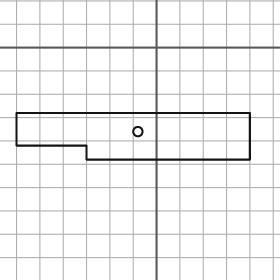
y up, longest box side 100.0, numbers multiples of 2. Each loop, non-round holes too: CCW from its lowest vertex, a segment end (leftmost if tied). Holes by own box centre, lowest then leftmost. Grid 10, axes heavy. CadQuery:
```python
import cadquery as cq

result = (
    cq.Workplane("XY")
    .moveTo(-30.0, -48.0)
    .lineTo(40.0, -48.0)
    .lineTo(40.0, -28.0)
    .lineTo(-60.0, -28.0)
    .lineTo(-60.0, -42.0)
    .lineTo(-30.0, -42.0)
    .close()
    .moveTo(-8.0, -36.0)
    .circle(2.0)
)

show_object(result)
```